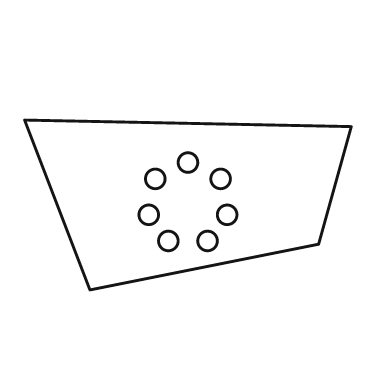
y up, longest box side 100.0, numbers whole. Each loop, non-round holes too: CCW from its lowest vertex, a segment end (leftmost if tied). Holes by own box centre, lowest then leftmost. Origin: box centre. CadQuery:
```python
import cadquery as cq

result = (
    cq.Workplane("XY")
    .moveTo(-30.0, -26.0)
    .lineTo(40.0, -12.0)
    .lineTo(50.0, 24.0)
    .lineTo(-50.0, 26.0)
    .close()
    .moveTo(-6.0, -11.0)
    .circle(3.0)
    .moveTo(6.0, -11.0)
    .circle(3.0)
    .moveTo(-12.0, -3.0)
    .circle(3.0)
    .moveTo(12.0, -3.0)
    .circle(3.0)
    .moveTo(-10.0, 8.0)
    .circle(3.0)
    .moveTo(10.0, 8.0)
    .circle(3.0)
    .moveTo(0.0, 13.0)
    .circle(3.0)
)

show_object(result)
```